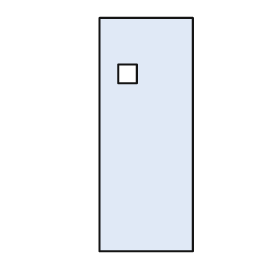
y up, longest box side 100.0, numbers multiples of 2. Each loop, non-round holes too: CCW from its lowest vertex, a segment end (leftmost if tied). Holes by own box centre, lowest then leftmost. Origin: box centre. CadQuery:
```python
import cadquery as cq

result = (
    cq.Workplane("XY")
    .moveTo(-20.0, -50.0)
    .lineTo(20.0, -50.0)
    .lineTo(20.0, 50.0)
    .lineTo(-20.0, 50.0)
    .close()
    .moveTo(-12.0, 22.0)
    .lineTo(-4.0, 22.0)
    .lineTo(-4.0, 30.0)
    .lineTo(-12.0, 30.0)
    .close()
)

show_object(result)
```